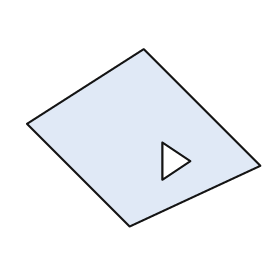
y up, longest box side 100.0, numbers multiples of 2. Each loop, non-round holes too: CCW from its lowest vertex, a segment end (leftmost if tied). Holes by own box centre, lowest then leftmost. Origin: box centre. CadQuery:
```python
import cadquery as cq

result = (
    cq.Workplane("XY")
    .moveTo(-6.0, -38.0)
    .lineTo(50.0, -12.0)
    .lineTo(0.0, 38.0)
    .lineTo(-50.0, 6.0)
    .close()
    .moveTo(8.0, -18.0)
    .lineTo(20.0, -10.0)
    .lineTo(8.0, -2.0)
    .close()
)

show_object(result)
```